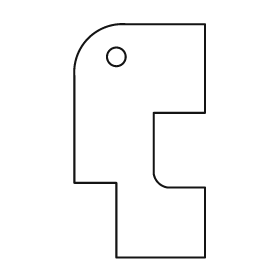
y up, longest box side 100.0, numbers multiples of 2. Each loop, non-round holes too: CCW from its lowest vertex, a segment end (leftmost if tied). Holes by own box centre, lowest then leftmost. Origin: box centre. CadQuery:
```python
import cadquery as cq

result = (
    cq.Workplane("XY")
    .moveTo(-10.0, -50.0)
    .lineTo(28.0, -50.0)
    .lineTo(28.0, -20.0)
    .lineTo(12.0, -20.0)
    .threePointArc((8.0, -18.0), (6.0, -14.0))
    .lineTo(6.0, 12.0)
    .lineTo(28.0, 12.0)
    .lineTo(28.0, 50.0)
    .lineTo(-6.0, 50.0)
    .threePointArc((-22.0, 44.0), (-28.0, 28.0))
    .lineTo(-28.0, -18.0)
    .lineTo(-10.0, -18.0)
    .close()
    .moveTo(-10.0, 36.0)
    .circle(4.0)
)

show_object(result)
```